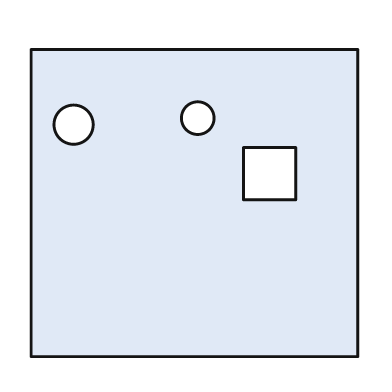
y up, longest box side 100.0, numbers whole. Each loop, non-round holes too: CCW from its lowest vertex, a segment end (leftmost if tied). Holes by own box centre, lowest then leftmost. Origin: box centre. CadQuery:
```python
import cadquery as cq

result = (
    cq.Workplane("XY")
    .moveTo(-50.0, -47.0)
    .lineTo(50.0, -47.0)
    .lineTo(50.0, 47.0)
    .lineTo(-50.0, 47.0)
    .close()
    .moveTo(15.0, 1.0)
    .lineTo(31.0, 1.0)
    .lineTo(31.0, 17.0)
    .lineTo(15.0, 17.0)
    .close()
    .moveTo(-37.0, 24.0)
    .circle(6.0)
    .moveTo(1.0, 26.0)
    .circle(5.0)
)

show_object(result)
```